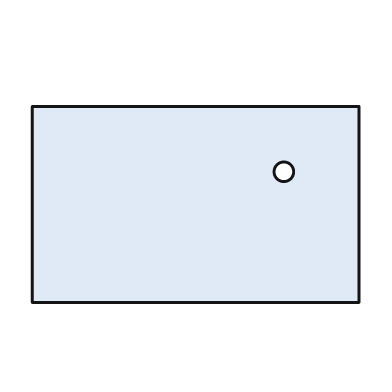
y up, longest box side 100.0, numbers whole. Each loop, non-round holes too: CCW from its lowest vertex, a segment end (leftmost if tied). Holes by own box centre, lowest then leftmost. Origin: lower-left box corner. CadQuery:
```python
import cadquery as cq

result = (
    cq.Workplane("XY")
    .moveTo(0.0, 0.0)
    .lineTo(100.0, 0.0)
    .lineTo(100.0, 60.0)
    .lineTo(0.0, 60.0)
    .close()
    .moveTo(77.0, 40.0)
    .circle(3.0)
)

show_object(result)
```